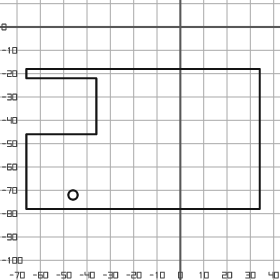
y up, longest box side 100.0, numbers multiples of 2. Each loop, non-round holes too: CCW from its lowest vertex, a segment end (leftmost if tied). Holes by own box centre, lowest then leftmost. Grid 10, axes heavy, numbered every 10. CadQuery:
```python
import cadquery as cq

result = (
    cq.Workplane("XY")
    .moveTo(-66.0, -78.0)
    .lineTo(34.0, -78.0)
    .lineTo(34.0, -18.0)
    .lineTo(-66.0, -18.0)
    .lineTo(-66.0, -22.0)
    .lineTo(-36.0, -22.0)
    .lineTo(-36.0, -46.0)
    .lineTo(-66.0, -46.0)
    .close()
    .moveTo(-46.0, -72.0)
    .circle(2.0)
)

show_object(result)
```